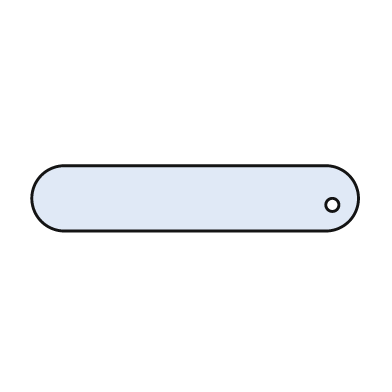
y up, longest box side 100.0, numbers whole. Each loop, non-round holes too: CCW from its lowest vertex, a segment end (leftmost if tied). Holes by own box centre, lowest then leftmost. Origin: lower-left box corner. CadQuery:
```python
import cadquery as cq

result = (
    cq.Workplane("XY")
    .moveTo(10.0, 0.0)
    .lineTo(90.0, 0.0)
    .threePointArc((100.0, 10.0), (90.0, 20.0))
    .lineTo(10.0, 20.0)
    .threePointArc((0.0, 10.0), (10.0, 0.0))
    .close()
    .moveTo(92.0, 8.0)
    .circle(2.0)
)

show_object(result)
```